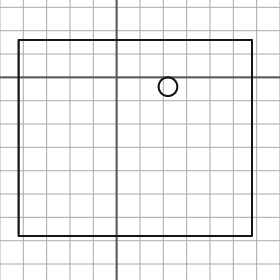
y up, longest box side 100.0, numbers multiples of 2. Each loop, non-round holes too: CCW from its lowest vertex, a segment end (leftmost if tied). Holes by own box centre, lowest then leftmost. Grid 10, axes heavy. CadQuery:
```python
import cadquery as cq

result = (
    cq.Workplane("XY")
    .moveTo(-42.0, -68.0)
    .lineTo(58.0, -68.0)
    .lineTo(58.0, 16.0)
    .lineTo(-42.0, 16.0)
    .close()
    .moveTo(22.0, -4.0)
    .circle(4.0)
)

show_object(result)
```